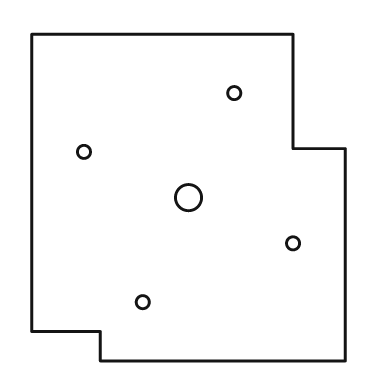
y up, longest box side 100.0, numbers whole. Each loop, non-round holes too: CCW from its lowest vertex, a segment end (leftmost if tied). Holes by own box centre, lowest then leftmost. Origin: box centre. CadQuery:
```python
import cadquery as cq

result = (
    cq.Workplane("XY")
    .moveTo(-27.0, -50.0)
    .lineTo(48.0, -50.0)
    .lineTo(48.0, 15.0)
    .lineTo(32.0, 15.0)
    .lineTo(32.0, 50.0)
    .lineTo(-48.0, 50.0)
    .lineTo(-48.0, -41.0)
    .lineTo(-27.0, -41.0)
    .close()
    .moveTo(-14.0, -32.0)
    .circle(2.0)
    .moveTo(32.0, -14.0)
    .circle(2.0)
    .moveTo(0.0, 0.0)
    .circle(4.0)
    .moveTo(-32.0, 14.0)
    .circle(2.0)
    .moveTo(14.0, 32.0)
    .circle(2.0)
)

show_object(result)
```